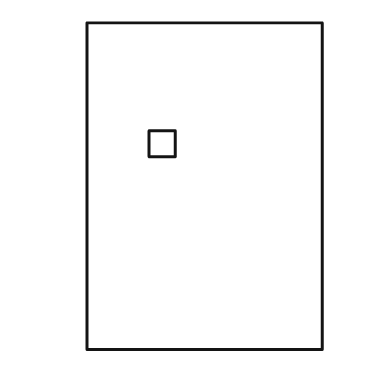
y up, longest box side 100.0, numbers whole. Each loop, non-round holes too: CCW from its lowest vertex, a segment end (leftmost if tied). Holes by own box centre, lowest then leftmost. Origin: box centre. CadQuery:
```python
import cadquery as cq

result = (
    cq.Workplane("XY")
    .moveTo(-36.0, -50.0)
    .lineTo(36.0, -50.0)
    .lineTo(36.0, 50.0)
    .lineTo(-36.0, 50.0)
    .close()
    .moveTo(-17.0, 9.0)
    .lineTo(-9.0, 9.0)
    .lineTo(-9.0, 17.0)
    .lineTo(-17.0, 17.0)
    .close()
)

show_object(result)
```